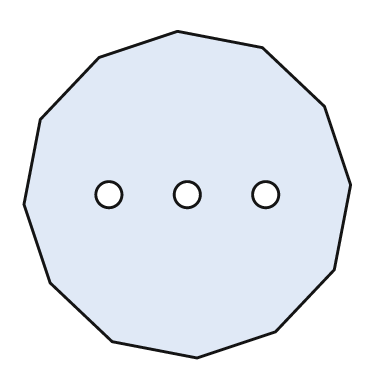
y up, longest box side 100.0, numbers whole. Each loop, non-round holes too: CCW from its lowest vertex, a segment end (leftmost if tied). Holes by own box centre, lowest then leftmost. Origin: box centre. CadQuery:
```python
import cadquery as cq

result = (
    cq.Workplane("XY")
    .moveTo(3.0, -50.0)
    .lineTo(27.0, -42.0)
    .lineTo(45.0, -23.0)
    .lineTo(50.0, 3.0)
    .lineTo(42.0, 27.0)
    .lineTo(23.0, 45.0)
    .lineTo(-3.0, 50.0)
    .lineTo(-27.0, 42.0)
    .lineTo(-45.0, 23.0)
    .lineTo(-50.0, -3.0)
    .lineTo(-42.0, -27.0)
    .lineTo(-23.0, -45.0)
    .close()
    .moveTo(-24.0, 0.0)
    .circle(4.0)
    .moveTo(0.0, 0.0)
    .circle(4.0)
    .moveTo(24.0, 0.0)
    .circle(4.0)
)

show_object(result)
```